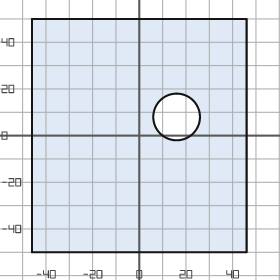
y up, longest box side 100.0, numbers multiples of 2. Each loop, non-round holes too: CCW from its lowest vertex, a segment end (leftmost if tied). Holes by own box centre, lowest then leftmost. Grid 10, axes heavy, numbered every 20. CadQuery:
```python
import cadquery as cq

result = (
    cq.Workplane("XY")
    .moveTo(-46.0, -50.0)
    .lineTo(46.0, -50.0)
    .lineTo(46.0, 50.0)
    .lineTo(-46.0, 50.0)
    .close()
    .moveTo(16.0, 8.0)
    .circle(10.0)
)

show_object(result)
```